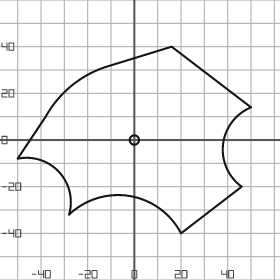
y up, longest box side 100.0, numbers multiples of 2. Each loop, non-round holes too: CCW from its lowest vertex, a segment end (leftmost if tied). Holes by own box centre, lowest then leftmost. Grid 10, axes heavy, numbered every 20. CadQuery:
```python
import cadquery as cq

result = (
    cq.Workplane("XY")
    .moveTo(20.0, -40.0)
    .lineTo(46.0, -20.0)
    .threePointArc((38.0, -2.0), (50.0, 14.0))
    .lineTo(16.0, 40.0)
    .lineTo(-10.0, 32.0)
    .threePointArc((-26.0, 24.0), (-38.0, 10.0))
    .lineTo(-50.0, -8.0)
    .threePointArc((-32.0, -14.0), (-28.0, -32.0))
    .threePointArc((-2.0, -24.0), (20.0, -40.0))
    .close()
    .moveTo(0.0, 0.0)
    .circle(2.0)
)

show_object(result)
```